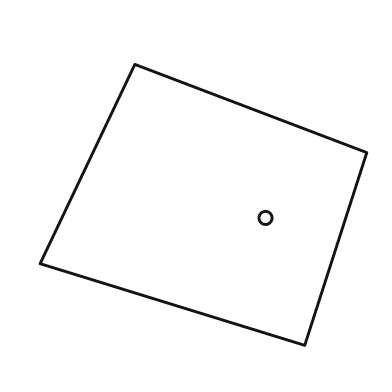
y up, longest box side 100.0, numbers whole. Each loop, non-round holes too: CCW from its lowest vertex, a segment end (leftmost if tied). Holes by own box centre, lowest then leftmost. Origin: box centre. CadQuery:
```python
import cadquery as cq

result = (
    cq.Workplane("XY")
    .moveTo(31.0, -43.0)
    .lineTo(50.0, 16.0)
    .lineTo(-21.0, 43.0)
    .lineTo(-50.0, -18.0)
    .close()
    .moveTo(19.0, -4.0)
    .circle(2.0)
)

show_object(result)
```